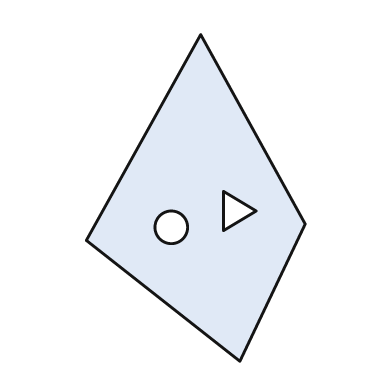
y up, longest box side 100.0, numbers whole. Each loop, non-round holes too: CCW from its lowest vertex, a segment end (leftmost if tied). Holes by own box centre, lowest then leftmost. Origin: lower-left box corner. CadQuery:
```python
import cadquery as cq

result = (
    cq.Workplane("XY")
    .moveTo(47.0, 0.0)
    .lineTo(67.0, 42.0)
    .lineTo(35.0, 100.0)
    .lineTo(0.0, 37.0)
    .close()
    .moveTo(26.0, 41.0)
    .circle(5.0)
    .moveTo(42.0, 40.0)
    .lineTo(52.0, 46.0)
    .lineTo(42.0, 52.0)
    .close()
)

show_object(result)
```